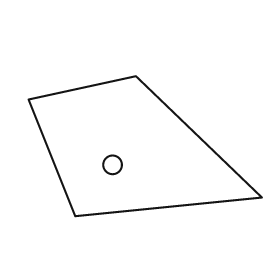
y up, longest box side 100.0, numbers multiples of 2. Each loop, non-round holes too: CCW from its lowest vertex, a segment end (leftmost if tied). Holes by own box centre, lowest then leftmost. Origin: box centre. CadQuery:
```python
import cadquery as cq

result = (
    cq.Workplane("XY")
    .moveTo(-30.0, -30.0)
    .lineTo(50.0, -22.0)
    .lineTo(-4.0, 30.0)
    .lineTo(-50.0, 20.0)
    .close()
    .moveTo(-14.0, -8.0)
    .circle(4.0)
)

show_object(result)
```